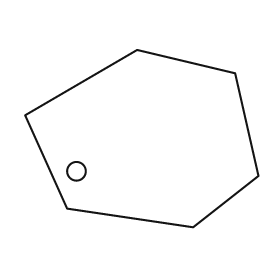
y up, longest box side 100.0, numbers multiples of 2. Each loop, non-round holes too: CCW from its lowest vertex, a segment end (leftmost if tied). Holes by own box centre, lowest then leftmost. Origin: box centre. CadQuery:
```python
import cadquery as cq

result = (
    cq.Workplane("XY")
    .moveTo(22.0, -38.0)
    .lineTo(50.0, -16.0)
    .lineTo(40.0, 28.0)
    .lineTo(-2.0, 38.0)
    .lineTo(-50.0, 10.0)
    .lineTo(-32.0, -30.0)
    .close()
    .moveTo(-28.0, -14.0)
    .circle(4.0)
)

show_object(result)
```